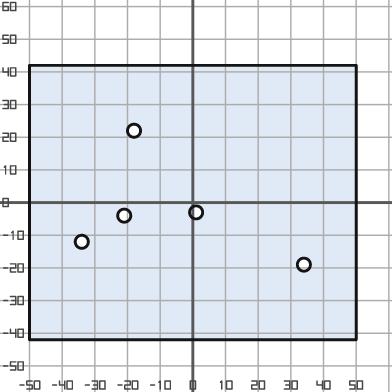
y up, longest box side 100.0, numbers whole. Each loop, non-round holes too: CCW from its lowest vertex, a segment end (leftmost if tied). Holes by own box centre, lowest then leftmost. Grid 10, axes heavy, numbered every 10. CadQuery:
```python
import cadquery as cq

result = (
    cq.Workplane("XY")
    .moveTo(-50.0, -42.0)
    .lineTo(50.0, -42.0)
    .lineTo(50.0, 42.0)
    .lineTo(-50.0, 42.0)
    .close()
    .moveTo(34.0, -19.0)
    .circle(2.0)
    .moveTo(-34.0, -12.0)
    .circle(2.0)
    .moveTo(-21.0, -4.0)
    .circle(2.0)
    .moveTo(1.0, -3.0)
    .circle(2.0)
    .moveTo(-18.0, 22.0)
    .circle(2.0)
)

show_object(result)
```